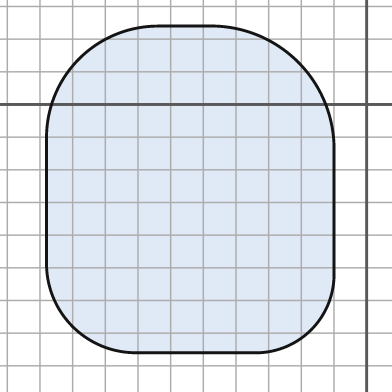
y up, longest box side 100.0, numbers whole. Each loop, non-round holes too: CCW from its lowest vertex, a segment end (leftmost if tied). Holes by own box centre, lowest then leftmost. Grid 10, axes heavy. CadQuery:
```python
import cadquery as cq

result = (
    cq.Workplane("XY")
    .moveTo(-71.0, -76.0)
    .lineTo(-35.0, -76.0)
    .threePointArc((-17.0, -69.0), (-10.0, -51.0))
    .lineTo(-10.0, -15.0)
    .threePointArc((-21.0, 13.0), (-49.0, 24.0))
    .lineTo(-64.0, 24.0)
    .threePointArc((-88.0, 14.0), (-98.0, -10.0))
    .lineTo(-98.0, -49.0)
    .threePointArc((-90.0, -68.0), (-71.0, -76.0))
    .close()
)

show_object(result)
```